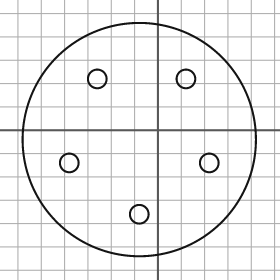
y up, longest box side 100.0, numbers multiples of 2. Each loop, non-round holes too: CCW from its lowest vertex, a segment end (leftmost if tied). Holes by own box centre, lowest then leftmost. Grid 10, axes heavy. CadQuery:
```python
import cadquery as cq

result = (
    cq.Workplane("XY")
    .moveTo(-8.0, -4.0)
    .circle(50.0)
    .moveTo(-8.0, -36.0)
    .circle(4.0)
    .moveTo(-38.0, -14.0)
    .circle(4.0)
    .moveTo(22.0, -14.0)
    .circle(4.0)
    .moveTo(-26.0, 22.0)
    .circle(4.0)
    .moveTo(12.0, 22.0)
    .circle(4.0)
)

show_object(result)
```